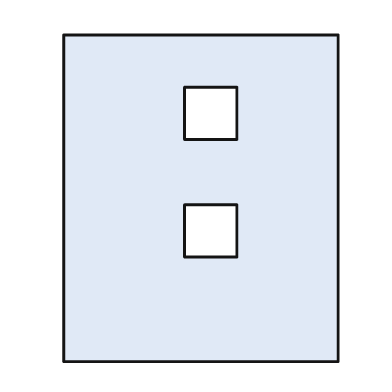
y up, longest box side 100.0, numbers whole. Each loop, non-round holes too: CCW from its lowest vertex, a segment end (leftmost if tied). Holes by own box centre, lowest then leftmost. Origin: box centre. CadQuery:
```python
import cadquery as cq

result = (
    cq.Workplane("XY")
    .moveTo(-42.0, -50.0)
    .lineTo(42.0, -50.0)
    .lineTo(42.0, 50.0)
    .lineTo(-42.0, 50.0)
    .close()
    .moveTo(-5.0, -18.0)
    .lineTo(11.0, -18.0)
    .lineTo(11.0, -2.0)
    .lineTo(-5.0, -2.0)
    .close()
    .moveTo(-5.0, 18.0)
    .lineTo(11.0, 18.0)
    .lineTo(11.0, 34.0)
    .lineTo(-5.0, 34.0)
    .close()
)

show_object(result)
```